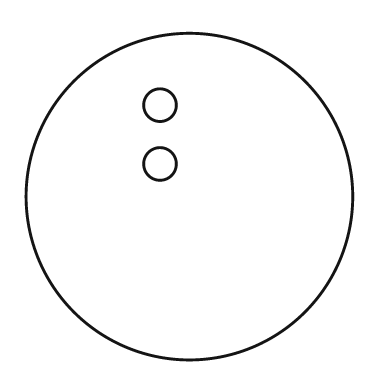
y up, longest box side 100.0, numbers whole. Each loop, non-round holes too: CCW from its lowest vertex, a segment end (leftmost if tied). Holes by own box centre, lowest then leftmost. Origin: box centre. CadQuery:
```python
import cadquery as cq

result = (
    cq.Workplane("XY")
    .moveTo(0.0, 0.0)
    .circle(50.0)
    .moveTo(-9.0, 10.0)
    .circle(5.0)
    .moveTo(-9.0, 28.0)
    .circle(5.0)
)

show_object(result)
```